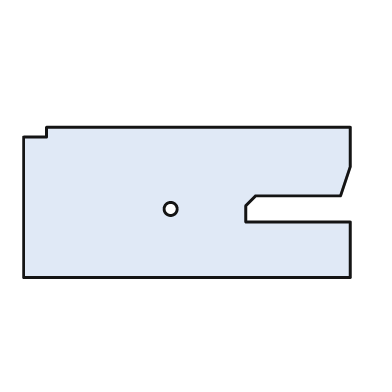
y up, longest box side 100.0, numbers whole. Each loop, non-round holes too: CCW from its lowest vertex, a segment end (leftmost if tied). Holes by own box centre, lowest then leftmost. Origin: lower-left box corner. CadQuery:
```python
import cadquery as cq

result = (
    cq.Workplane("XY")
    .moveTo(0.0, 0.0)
    .lineTo(100.0, 0.0)
    .lineTo(100.0, 17.0)
    .lineTo(68.0, 17.0)
    .lineTo(68.0, 22.0)
    .lineTo(71.0, 25.0)
    .lineTo(97.0, 25.0)
    .lineTo(100.0, 34.0)
    .lineTo(100.0, 46.0)
    .lineTo(7.0, 46.0)
    .lineTo(7.0, 43.0)
    .lineTo(0.0, 43.0)
    .close()
    .moveTo(45.0, 21.0)
    .circle(2.0)
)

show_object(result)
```